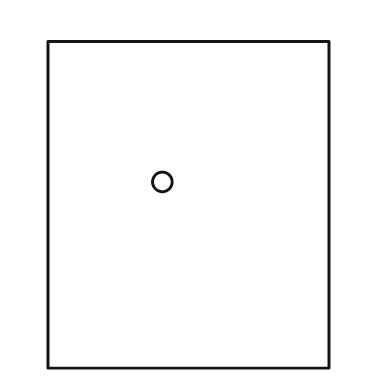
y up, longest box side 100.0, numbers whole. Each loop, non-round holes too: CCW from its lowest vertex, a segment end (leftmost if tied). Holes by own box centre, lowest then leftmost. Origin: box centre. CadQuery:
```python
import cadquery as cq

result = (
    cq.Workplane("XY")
    .moveTo(-43.0, -50.0)
    .lineTo(43.0, -50.0)
    .lineTo(43.0, 50.0)
    .lineTo(-43.0, 50.0)
    .close()
    .moveTo(-8.0, 7.0)
    .circle(3.0)
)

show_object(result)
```